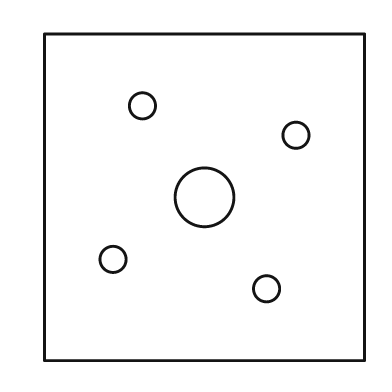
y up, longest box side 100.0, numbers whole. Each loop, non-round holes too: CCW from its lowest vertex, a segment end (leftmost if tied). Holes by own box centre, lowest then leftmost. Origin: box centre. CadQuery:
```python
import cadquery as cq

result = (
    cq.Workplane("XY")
    .moveTo(-49.0, -50.0)
    .lineTo(49.0, -50.0)
    .lineTo(49.0, 50.0)
    .lineTo(-49.0, 50.0)
    .close()
    .moveTo(19.0, -28.0)
    .circle(4.0)
    .moveTo(-28.0, -19.0)
    .circle(4.0)
    .moveTo(0.0, 0.0)
    .circle(9.0)
    .moveTo(28.0, 19.0)
    .circle(4.0)
    .moveTo(-19.0, 28.0)
    .circle(4.0)
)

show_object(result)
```